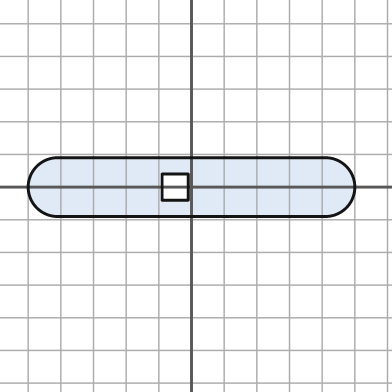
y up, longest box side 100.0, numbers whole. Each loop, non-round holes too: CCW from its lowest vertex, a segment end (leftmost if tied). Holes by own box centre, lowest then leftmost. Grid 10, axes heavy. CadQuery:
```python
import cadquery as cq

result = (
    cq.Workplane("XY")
    .moveTo(-41.0, -9.0)
    .lineTo(41.0, -9.0)
    .threePointArc((50.0, 0.0), (41.0, 9.0))
    .lineTo(-41.0, 9.0)
    .threePointArc((-50.0, 0.0), (-41.0, -9.0))
    .close()
    .moveTo(-9.0, -4.0)
    .lineTo(-1.0, -4.0)
    .lineTo(-1.0, 4.0)
    .lineTo(-9.0, 4.0)
    .close()
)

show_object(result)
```